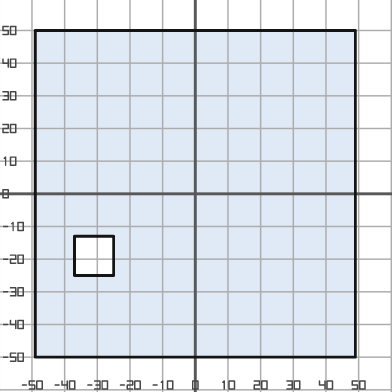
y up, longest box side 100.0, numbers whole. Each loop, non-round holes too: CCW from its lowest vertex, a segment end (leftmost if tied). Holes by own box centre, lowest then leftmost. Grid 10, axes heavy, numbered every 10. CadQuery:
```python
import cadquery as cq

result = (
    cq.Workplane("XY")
    .moveTo(-49.0, -50.0)
    .lineTo(49.0, -50.0)
    .lineTo(49.0, 50.0)
    .lineTo(-49.0, 50.0)
    .close()
    .moveTo(-37.0, -25.0)
    .lineTo(-25.0, -25.0)
    .lineTo(-25.0, -13.0)
    .lineTo(-37.0, -13.0)
    .close()
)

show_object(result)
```